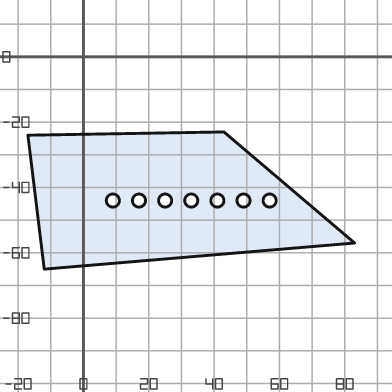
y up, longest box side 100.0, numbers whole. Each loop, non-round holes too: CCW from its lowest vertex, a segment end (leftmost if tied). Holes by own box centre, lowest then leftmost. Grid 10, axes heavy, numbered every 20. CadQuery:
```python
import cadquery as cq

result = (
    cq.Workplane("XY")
    .moveTo(-12.0, -65.0)
    .lineTo(83.0, -57.0)
    .lineTo(43.0, -23.0)
    .lineTo(-17.0, -24.0)
    .close()
    .moveTo(9.0, -44.0)
    .circle(2.0)
    .moveTo(17.0, -44.0)
    .circle(2.0)
    .moveTo(25.0, -44.0)
    .circle(2.0)
    .moveTo(33.0, -44.0)
    .circle(2.0)
    .moveTo(41.0, -44.0)
    .circle(2.0)
    .moveTo(49.0, -44.0)
    .circle(2.0)
    .moveTo(57.0, -44.0)
    .circle(2.0)
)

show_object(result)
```